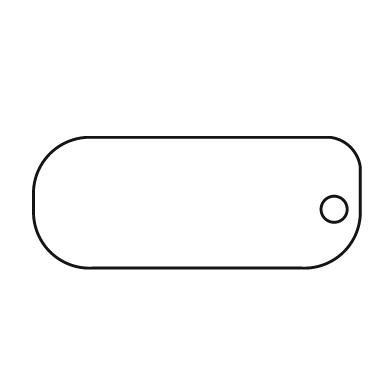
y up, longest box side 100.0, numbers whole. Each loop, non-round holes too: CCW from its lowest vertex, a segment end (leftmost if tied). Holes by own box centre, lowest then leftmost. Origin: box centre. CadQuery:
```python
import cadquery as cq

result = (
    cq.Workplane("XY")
    .moveTo(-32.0, -20.0)
    .lineTo(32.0, -20.0)
    .threePointArc((45.0, -15.0), (50.0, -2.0))
    .lineTo(50.0, 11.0)
    .threePointArc((47.0, 17.0), (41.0, 20.0))
    .lineTo(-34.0, 20.0)
    .threePointArc((-45.0, 15.0), (-50.0, 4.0))
    .lineTo(-50.0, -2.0)
    .threePointArc((-45.0, -15.0), (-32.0, -20.0))
    .close()
    .moveTo(42.0, -2.0)
    .circle(4.0)
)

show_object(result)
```